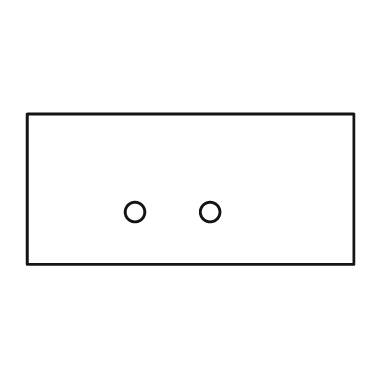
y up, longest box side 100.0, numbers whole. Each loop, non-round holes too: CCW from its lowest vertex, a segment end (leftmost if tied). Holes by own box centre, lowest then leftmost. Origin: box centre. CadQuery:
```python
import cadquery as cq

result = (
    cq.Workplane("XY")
    .moveTo(-50.0, -23.0)
    .lineTo(50.0, -23.0)
    .lineTo(50.0, 23.0)
    .lineTo(-50.0, 23.0)
    .close()
    .moveTo(-17.0, -7.0)
    .circle(3.0)
    .moveTo(6.0, -7.0)
    .circle(3.0)
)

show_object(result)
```